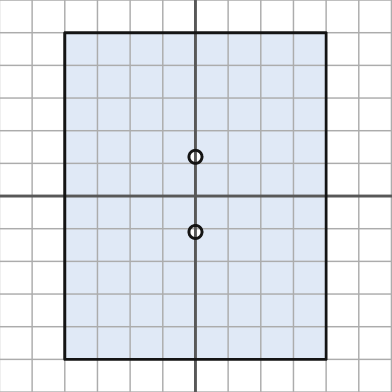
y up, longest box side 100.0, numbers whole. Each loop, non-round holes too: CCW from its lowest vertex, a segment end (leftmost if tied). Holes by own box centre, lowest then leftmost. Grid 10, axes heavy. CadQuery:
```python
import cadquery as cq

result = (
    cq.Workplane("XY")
    .moveTo(-40.0, -50.0)
    .lineTo(40.0, -50.0)
    .lineTo(40.0, 50.0)
    .lineTo(-40.0, 50.0)
    .close()
    .moveTo(0.0, -11.0)
    .circle(2.0)
    .moveTo(0.0, 12.0)
    .circle(2.0)
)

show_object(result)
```